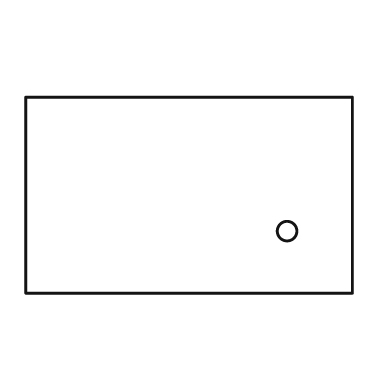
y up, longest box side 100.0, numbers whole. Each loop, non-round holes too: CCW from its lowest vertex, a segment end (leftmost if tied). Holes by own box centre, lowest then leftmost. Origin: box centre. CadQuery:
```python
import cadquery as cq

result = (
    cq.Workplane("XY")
    .moveTo(-50.0, -30.0)
    .lineTo(50.0, -30.0)
    .lineTo(50.0, 30.0)
    .lineTo(-50.0, 30.0)
    .close()
    .moveTo(30.0, -11.0)
    .circle(3.0)
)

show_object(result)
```